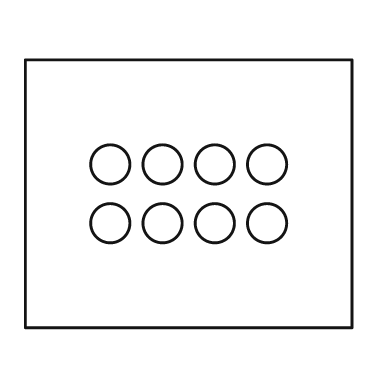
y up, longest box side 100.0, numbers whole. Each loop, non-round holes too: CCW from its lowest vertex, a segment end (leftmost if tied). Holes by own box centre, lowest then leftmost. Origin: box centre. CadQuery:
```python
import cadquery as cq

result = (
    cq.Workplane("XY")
    .moveTo(-50.0, -41.0)
    .lineTo(50.0, -41.0)
    .lineTo(50.0, 41.0)
    .lineTo(-50.0, 41.0)
    .close()
    .moveTo(-24.0, -9.0)
    .circle(6.0)
    .moveTo(-8.0, -9.0)
    .circle(6.0)
    .moveTo(8.0, -9.0)
    .circle(6.0)
    .moveTo(24.0, -9.0)
    .circle(6.0)
    .moveTo(-24.0, 9.0)
    .circle(6.0)
    .moveTo(-8.0, 9.0)
    .circle(6.0)
    .moveTo(8.0, 9.0)
    .circle(6.0)
    .moveTo(24.0, 9.0)
    .circle(6.0)
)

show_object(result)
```